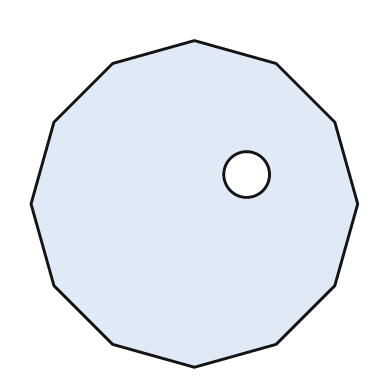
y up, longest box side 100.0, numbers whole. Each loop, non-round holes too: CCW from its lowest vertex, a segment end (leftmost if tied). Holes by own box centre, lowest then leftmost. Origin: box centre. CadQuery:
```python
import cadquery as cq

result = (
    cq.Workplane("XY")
    .moveTo(0.0, -50.0)
    .lineTo(25.0, -43.0)
    .lineTo(43.0, -25.0)
    .lineTo(50.0, 0.0)
    .lineTo(43.0, 25.0)
    .lineTo(25.0, 43.0)
    .lineTo(0.0, 50.0)
    .lineTo(-25.0, 43.0)
    .lineTo(-43.0, 25.0)
    .lineTo(-50.0, 0.0)
    .lineTo(-43.0, -25.0)
    .lineTo(-25.0, -43.0)
    .close()
    .moveTo(16.0, 9.0)
    .circle(7.0)
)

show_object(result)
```